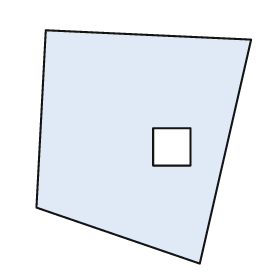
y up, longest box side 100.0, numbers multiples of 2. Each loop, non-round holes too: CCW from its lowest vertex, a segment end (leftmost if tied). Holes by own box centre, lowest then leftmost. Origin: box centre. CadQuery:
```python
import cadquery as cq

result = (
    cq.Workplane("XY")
    .moveTo(24.0, -50.0)
    .lineTo(46.0, 46.0)
    .lineTo(-42.0, 50.0)
    .lineTo(-46.0, -26.0)
    .close()
    .moveTo(4.0, -8.0)
    .lineTo(20.0, -8.0)
    .lineTo(20.0, 8.0)
    .lineTo(4.0, 8.0)
    .close()
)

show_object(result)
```